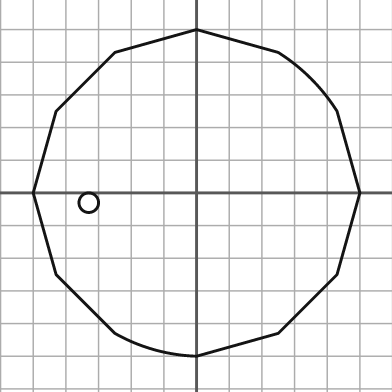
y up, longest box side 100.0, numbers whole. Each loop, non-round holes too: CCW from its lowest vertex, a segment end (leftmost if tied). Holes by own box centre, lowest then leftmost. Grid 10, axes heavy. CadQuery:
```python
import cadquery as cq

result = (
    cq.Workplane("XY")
    .moveTo(0.0, -50.0)
    .lineTo(25.0, -43.0)
    .lineTo(43.0, -25.0)
    .lineTo(50.0, 0.0)
    .lineTo(43.0, 25.0)
    .threePointArc((35.0, 35.0), (25.0, 43.0))
    .lineTo(0.0, 50.0)
    .lineTo(-25.0, 43.0)
    .lineTo(-43.0, 25.0)
    .lineTo(-50.0, 0.0)
    .lineTo(-43.0, -25.0)
    .lineTo(-25.0, -43.0)
    .threePointArc((-13.0, -48.0), (0.0, -50.0))
    .close()
    .moveTo(-33.0, -3.0)
    .circle(3.0)
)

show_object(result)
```